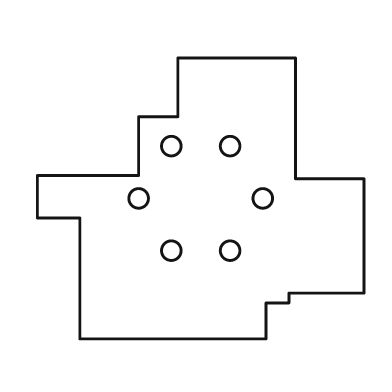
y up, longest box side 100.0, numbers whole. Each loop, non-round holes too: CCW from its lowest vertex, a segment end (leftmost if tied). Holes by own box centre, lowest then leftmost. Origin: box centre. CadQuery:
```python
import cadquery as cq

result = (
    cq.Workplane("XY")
    .moveTo(-37.0, -43.0)
    .lineTo(20.0, -43.0)
    .lineTo(20.0, -32.0)
    .lineTo(27.0, -32.0)
    .lineTo(27.0, -29.0)
    .lineTo(50.0, -29.0)
    .lineTo(50.0, 6.0)
    .lineTo(29.0, 6.0)
    .lineTo(29.0, 43.0)
    .lineTo(-7.0, 43.0)
    .lineTo(-7.0, 25.0)
    .lineTo(-19.0, 25.0)
    .lineTo(-19.0, 7.0)
    .lineTo(-50.0, 7.0)
    .lineTo(-50.0, -6.0)
    .lineTo(-37.0, -6.0)
    .close()
    .moveTo(-9.0, -16.0)
    .circle(3.0)
    .moveTo(9.0, -16.0)
    .circle(3.0)
    .moveTo(-19.0, 0.0)
    .circle(3.0)
    .moveTo(19.0, 0.0)
    .circle(3.0)
    .moveTo(-9.0, 16.0)
    .circle(3.0)
    .moveTo(9.0, 16.0)
    .circle(3.0)
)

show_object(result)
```